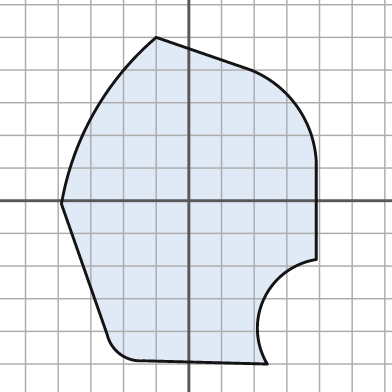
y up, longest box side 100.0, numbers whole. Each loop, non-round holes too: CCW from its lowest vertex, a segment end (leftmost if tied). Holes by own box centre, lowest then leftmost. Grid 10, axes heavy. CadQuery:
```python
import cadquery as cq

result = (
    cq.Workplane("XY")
    .moveTo(24.0, -50.0)
    .threePointArc((23.0, -30.0), (39.0, -18.0))
    .lineTo(39.0, 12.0)
    .threePointArc((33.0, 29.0), (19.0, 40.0))
    .lineTo(-10.0, 50.0)
    .threePointArc((-29.0, 27.0), (-39.0, -1.0))
    .lineTo(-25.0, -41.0)
    .threePointArc((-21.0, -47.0), (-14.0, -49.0))
    .close()
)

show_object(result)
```